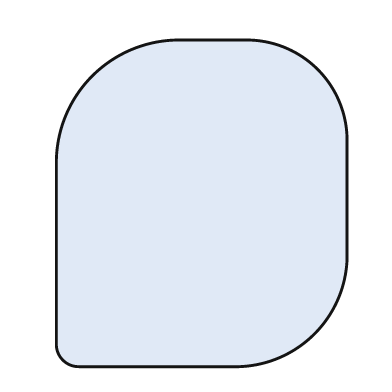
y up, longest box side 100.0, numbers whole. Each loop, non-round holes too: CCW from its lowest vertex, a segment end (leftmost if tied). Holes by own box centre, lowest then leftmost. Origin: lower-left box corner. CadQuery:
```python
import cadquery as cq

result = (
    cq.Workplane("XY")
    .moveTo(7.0, 0.0)
    .lineTo(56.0, 0.0)
    .threePointArc((79.0, 10.0), (89.0, 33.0))
    .lineTo(89.0, 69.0)
    .threePointArc((80.0, 91.0), (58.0, 100.0))
    .lineTo(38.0, 100.0)
    .threePointArc((11.0, 89.0), (0.0, 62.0))
    .lineTo(0.0, 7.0)
    .threePointArc((2.0, 2.0), (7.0, 0.0))
    .close()
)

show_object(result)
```